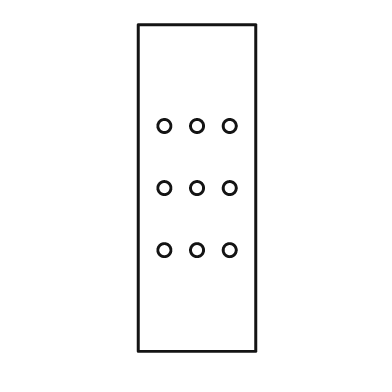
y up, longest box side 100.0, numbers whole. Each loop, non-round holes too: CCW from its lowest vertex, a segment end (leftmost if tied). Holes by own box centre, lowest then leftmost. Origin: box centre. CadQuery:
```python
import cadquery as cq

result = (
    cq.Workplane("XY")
    .moveTo(-18.0, -50.0)
    .lineTo(18.0, -50.0)
    .lineTo(18.0, 50.0)
    .lineTo(-18.0, 50.0)
    .close()
    .moveTo(-10.0, -19.0)
    .circle(2.0)
    .moveTo(0.0, -19.0)
    .circle(2.0)
    .moveTo(10.0, -19.0)
    .circle(2.0)
    .moveTo(-10.0, 0.0)
    .circle(2.0)
    .moveTo(0.0, 0.0)
    .circle(2.0)
    .moveTo(10.0, 0.0)
    .circle(2.0)
    .moveTo(-10.0, 19.0)
    .circle(2.0)
    .moveTo(0.0, 19.0)
    .circle(2.0)
    .moveTo(10.0, 19.0)
    .circle(2.0)
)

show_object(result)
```